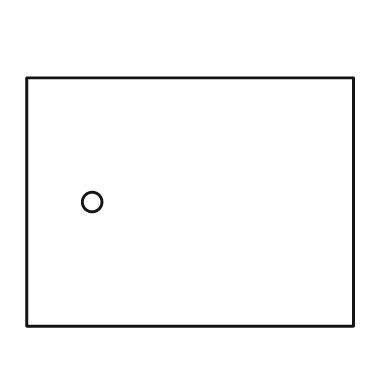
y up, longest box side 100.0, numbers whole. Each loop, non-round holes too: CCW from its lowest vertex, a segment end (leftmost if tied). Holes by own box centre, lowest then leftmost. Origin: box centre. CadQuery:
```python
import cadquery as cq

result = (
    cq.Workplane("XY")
    .moveTo(-50.0, -38.0)
    .lineTo(50.0, -38.0)
    .lineTo(50.0, 38.0)
    .lineTo(-50.0, 38.0)
    .close()
    .moveTo(-30.0, 0.0)
    .circle(3.0)
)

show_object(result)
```